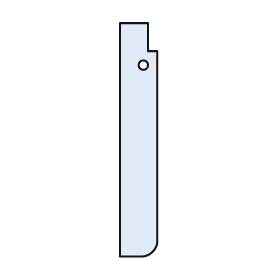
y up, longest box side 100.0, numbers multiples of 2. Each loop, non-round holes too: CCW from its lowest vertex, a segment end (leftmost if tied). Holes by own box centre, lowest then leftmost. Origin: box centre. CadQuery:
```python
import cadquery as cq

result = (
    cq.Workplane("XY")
    .moveTo(-8.0, -50.0)
    .lineTo(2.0, -50.0)
    .threePointArc((6.0, -48.0), (8.0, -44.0))
    .lineTo(8.0, 38.0)
    .lineTo(4.0, 38.0)
    .lineTo(4.0, 50.0)
    .lineTo(-8.0, 50.0)
    .close()
    .moveTo(2.0, 32.0)
    .circle(2.0)
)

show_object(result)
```